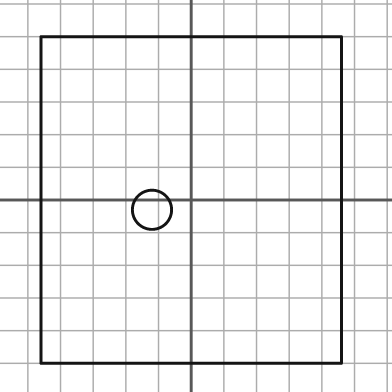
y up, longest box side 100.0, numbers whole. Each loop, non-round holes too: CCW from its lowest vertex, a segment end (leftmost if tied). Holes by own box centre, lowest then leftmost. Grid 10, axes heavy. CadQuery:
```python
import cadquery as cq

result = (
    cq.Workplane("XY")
    .moveTo(-46.0, -50.0)
    .lineTo(46.0, -50.0)
    .lineTo(46.0, 50.0)
    .lineTo(-46.0, 50.0)
    .close()
    .moveTo(-12.0, -3.0)
    .circle(6.0)
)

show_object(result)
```